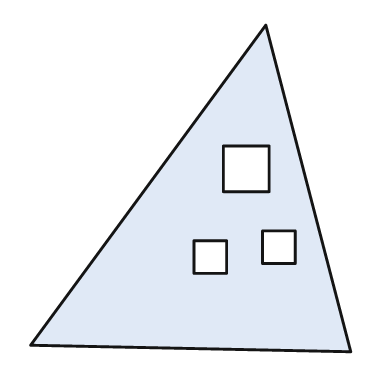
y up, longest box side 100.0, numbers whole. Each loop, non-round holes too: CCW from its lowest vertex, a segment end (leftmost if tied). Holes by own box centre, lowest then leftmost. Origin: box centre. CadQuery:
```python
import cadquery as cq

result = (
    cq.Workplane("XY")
    .moveTo(49.0, -50.0)
    .lineTo(23.0, 50.0)
    .lineTo(-49.0, -48.0)
    .close()
    .moveTo(1.0, -26.0)
    .lineTo(11.0, -26.0)
    .lineTo(11.0, -16.0)
    .lineTo(1.0, -16.0)
    .close()
    .moveTo(22.0, -23.0)
    .lineTo(32.0, -23.0)
    .lineTo(32.0, -13.0)
    .lineTo(22.0, -13.0)
    .close()
    .moveTo(10.0, -1.0)
    .lineTo(24.0, -1.0)
    .lineTo(24.0, 13.0)
    .lineTo(10.0, 13.0)
    .close()
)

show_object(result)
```